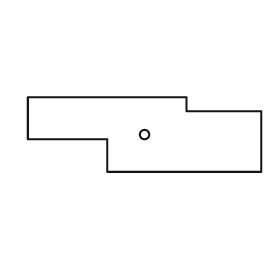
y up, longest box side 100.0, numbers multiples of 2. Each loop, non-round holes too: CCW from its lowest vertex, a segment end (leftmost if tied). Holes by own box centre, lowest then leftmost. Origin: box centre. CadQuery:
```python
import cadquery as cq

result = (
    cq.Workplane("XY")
    .moveTo(-16.0, -16.0)
    .lineTo(50.0, -16.0)
    .lineTo(50.0, 10.0)
    .lineTo(18.0, 10.0)
    .lineTo(18.0, 16.0)
    .lineTo(-50.0, 16.0)
    .lineTo(-50.0, -2.0)
    .lineTo(-16.0, -2.0)
    .close()
    .moveTo(0.0, 0.0)
    .circle(2.0)
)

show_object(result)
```